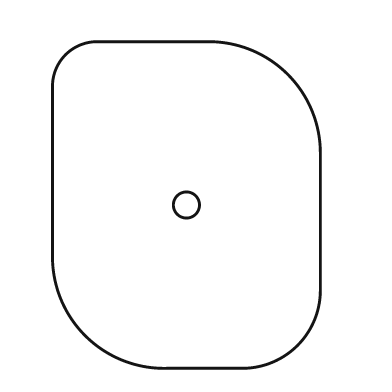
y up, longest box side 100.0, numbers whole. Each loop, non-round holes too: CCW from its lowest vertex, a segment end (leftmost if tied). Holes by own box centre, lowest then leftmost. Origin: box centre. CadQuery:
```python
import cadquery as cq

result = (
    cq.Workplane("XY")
    .moveTo(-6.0, -50.0)
    .lineTo(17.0, -50.0)
    .threePointArc((34.0, -43.0), (41.0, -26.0))
    .lineTo(41.0, 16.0)
    .threePointArc((31.0, 40.0), (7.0, 50.0))
    .lineTo(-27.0, 50.0)
    .threePointArc((-37.0, 46.0), (-41.0, 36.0))
    .lineTo(-41.0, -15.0)
    .threePointArc((-31.0, -40.0), (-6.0, -50.0))
    .close()
    .moveTo(0.0, 0.0)
    .circle(4.0)
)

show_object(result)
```